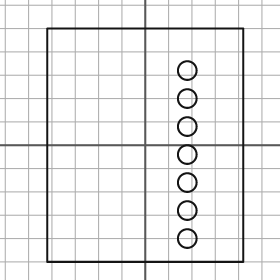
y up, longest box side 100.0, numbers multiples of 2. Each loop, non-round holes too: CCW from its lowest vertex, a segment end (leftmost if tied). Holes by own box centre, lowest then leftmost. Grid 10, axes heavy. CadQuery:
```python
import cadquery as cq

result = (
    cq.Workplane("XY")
    .moveTo(-42.0, -50.0)
    .lineTo(42.0, -50.0)
    .lineTo(42.0, 50.0)
    .lineTo(-42.0, 50.0)
    .close()
    .moveTo(18.0, -40.0)
    .circle(4.0)
    .moveTo(18.0, -28.0)
    .circle(4.0)
    .moveTo(18.0, -16.0)
    .circle(4.0)
    .moveTo(18.0, -4.0)
    .circle(4.0)
    .moveTo(18.0, 8.0)
    .circle(4.0)
    .moveTo(18.0, 20.0)
    .circle(4.0)
    .moveTo(18.0, 32.0)
    .circle(4.0)
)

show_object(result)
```